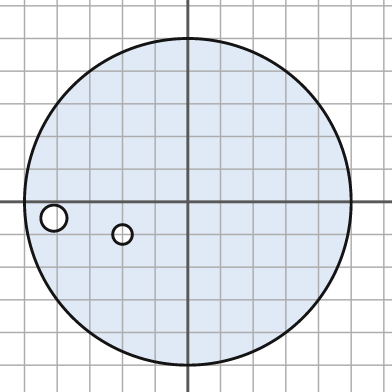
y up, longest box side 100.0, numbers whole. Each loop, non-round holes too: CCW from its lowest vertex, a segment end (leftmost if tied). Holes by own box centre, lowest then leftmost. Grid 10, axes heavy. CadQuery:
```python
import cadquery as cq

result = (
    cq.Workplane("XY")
    .moveTo(0.0, 0.0)
    .circle(50.0)
    .moveTo(-20.0, -10.0)
    .circle(3.0)
    .moveTo(-41.0, -5.0)
    .circle(4.0)
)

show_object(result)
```